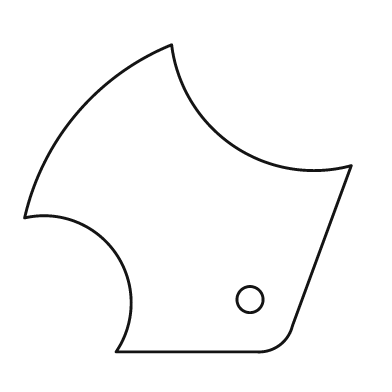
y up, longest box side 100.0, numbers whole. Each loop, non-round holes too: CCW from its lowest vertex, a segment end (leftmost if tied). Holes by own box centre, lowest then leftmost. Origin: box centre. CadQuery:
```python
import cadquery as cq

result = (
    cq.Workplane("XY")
    .moveTo(-22.0, -47.0)
    .lineTo(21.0, -47.0)
    .threePointArc((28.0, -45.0), (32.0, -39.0))
    .lineTo(50.0, 10.0)
    .threePointArc((14.0, 16.0), (-5.0, 47.0))
    .threePointArc((-34.0, 26.0), (-50.0, -6.0))
    .threePointArc((-22.0, -17.0), (-22.0, -47.0))
    .close()
    .moveTo(19.0, -31.0)
    .circle(4.0)
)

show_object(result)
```